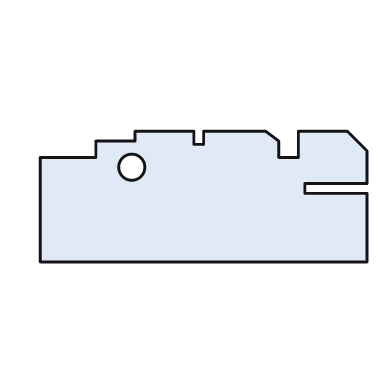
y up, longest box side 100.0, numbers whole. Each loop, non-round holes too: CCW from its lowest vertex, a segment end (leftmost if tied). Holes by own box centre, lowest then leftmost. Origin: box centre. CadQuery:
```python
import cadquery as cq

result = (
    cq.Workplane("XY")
    .moveTo(-50.0, -20.0)
    .lineTo(50.0, -20.0)
    .lineTo(50.0, 1.0)
    .lineTo(31.0, 1.0)
    .lineTo(31.0, 4.0)
    .lineTo(50.0, 4.0)
    .lineTo(50.0, 14.0)
    .lineTo(44.0, 20.0)
    .lineTo(29.0, 20.0)
    .lineTo(29.0, 12.0)
    .lineTo(23.0, 12.0)
    .lineTo(23.0, 17.0)
    .lineTo(19.0, 20.0)
    .lineTo(0.0, 20.0)
    .lineTo(0.0, 16.0)
    .lineTo(-3.0, 16.0)
    .lineTo(-3.0, 20.0)
    .lineTo(-21.0, 20.0)
    .lineTo(-21.0, 17.0)
    .lineTo(-33.0, 17.0)
    .lineTo(-33.0, 12.0)
    .lineTo(-50.0, 12.0)
    .close()
    .moveTo(-22.0, 9.0)
    .circle(4.0)
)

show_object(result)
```